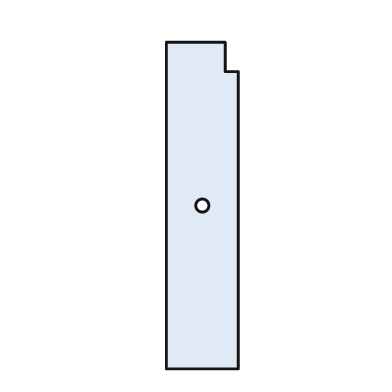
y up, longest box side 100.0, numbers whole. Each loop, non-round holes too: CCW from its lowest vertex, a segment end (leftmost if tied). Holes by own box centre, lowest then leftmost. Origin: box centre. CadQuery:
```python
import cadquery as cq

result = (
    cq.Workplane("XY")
    .moveTo(-11.0, -50.0)
    .lineTo(11.0, -50.0)
    .lineTo(11.0, 41.0)
    .lineTo(7.0, 41.0)
    .lineTo(7.0, 50.0)
    .lineTo(-11.0, 50.0)
    .close()
    .moveTo(0.0, 0.0)
    .circle(2.0)
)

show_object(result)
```